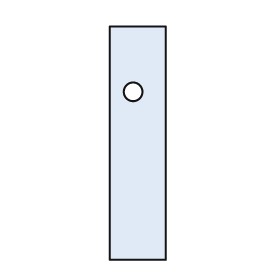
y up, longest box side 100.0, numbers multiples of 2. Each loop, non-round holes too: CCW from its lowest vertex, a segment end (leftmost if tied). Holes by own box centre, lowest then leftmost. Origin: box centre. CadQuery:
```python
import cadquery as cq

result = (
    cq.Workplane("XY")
    .moveTo(-12.0, -50.0)
    .lineTo(12.0, -50.0)
    .lineTo(12.0, 50.0)
    .lineTo(-12.0, 50.0)
    .close()
    .moveTo(-2.0, 22.0)
    .circle(4.0)
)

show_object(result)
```